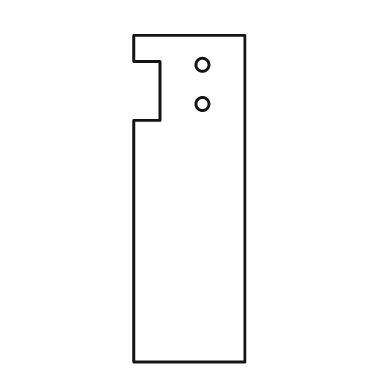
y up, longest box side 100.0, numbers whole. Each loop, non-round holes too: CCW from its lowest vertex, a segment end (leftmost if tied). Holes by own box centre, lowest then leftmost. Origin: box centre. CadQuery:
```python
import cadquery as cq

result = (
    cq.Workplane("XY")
    .moveTo(-17.0, -50.0)
    .lineTo(17.0, -50.0)
    .lineTo(17.0, 50.0)
    .lineTo(-17.0, 50.0)
    .lineTo(-17.0, 42.0)
    .lineTo(-9.0, 42.0)
    .lineTo(-9.0, 24.0)
    .lineTo(-17.0, 24.0)
    .close()
    .moveTo(4.0, 29.0)
    .circle(2.0)
    .moveTo(4.0, 41.0)
    .circle(2.0)
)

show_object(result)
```